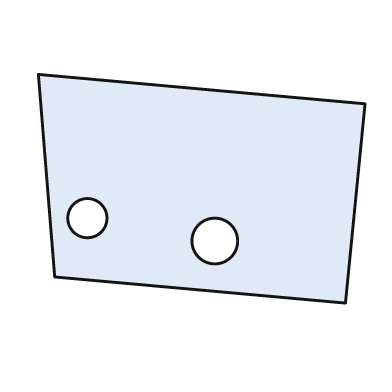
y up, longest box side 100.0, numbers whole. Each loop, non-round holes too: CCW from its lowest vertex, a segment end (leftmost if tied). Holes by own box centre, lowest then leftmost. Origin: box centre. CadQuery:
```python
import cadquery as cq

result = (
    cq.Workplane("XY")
    .moveTo(44.0, -35.0)
    .lineTo(50.0, 26.0)
    .lineTo(-50.0, 35.0)
    .lineTo(-45.0, -27.0)
    .close()
    .moveTo(4.0, -16.0)
    .circle(7.0)
    .moveTo(-35.0, -9.0)
    .circle(6.0)
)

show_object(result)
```